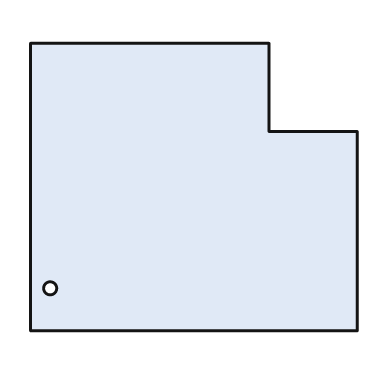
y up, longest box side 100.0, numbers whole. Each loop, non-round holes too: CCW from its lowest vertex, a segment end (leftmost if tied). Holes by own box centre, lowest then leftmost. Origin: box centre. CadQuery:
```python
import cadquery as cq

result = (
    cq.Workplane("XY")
    .moveTo(-50.0, -44.0)
    .lineTo(50.0, -44.0)
    .lineTo(50.0, 17.0)
    .lineTo(23.0, 17.0)
    .lineTo(23.0, 44.0)
    .lineTo(-50.0, 44.0)
    .close()
    .moveTo(-44.0, -31.0)
    .circle(2.0)
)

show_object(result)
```